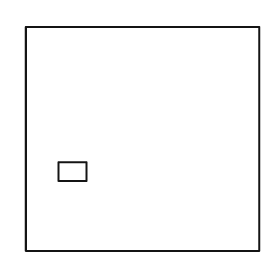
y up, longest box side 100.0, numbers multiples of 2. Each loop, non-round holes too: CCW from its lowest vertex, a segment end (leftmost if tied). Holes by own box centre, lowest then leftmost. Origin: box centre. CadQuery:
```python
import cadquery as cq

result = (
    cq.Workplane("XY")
    .moveTo(-50.0, -48.0)
    .lineTo(50.0, -48.0)
    .lineTo(50.0, 48.0)
    .lineTo(-50.0, 48.0)
    .close()
    .moveTo(-36.0, -18.0)
    .lineTo(-24.0, -18.0)
    .lineTo(-24.0, -10.0)
    .lineTo(-36.0, -10.0)
    .close()
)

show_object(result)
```